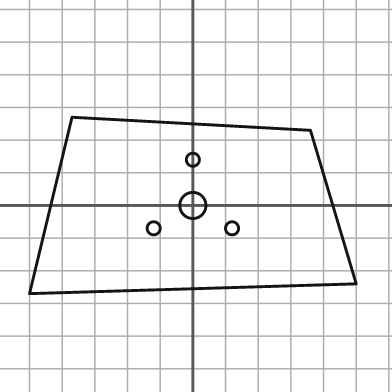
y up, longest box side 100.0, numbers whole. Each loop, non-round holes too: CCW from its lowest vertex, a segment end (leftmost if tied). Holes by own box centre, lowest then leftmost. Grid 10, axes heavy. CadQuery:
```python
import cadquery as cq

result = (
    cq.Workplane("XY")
    .moveTo(-50.0, -27.0)
    .lineTo(50.0, -24.0)
    .lineTo(36.0, 23.0)
    .lineTo(-37.0, 27.0)
    .close()
    .moveTo(-12.0, -7.0)
    .circle(2.0)
    .moveTo(12.0, -7.0)
    .circle(2.0)
    .moveTo(0.0, 0.0)
    .circle(4.0)
    .moveTo(0.0, 14.0)
    .circle(2.0)
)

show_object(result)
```